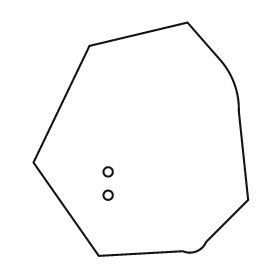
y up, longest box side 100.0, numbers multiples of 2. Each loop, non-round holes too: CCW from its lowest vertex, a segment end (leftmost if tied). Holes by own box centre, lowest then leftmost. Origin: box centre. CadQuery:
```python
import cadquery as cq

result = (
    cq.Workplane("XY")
    .moveTo(-18.0, -50.0)
    .lineTo(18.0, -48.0)
    .threePointArc((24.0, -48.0), (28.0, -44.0))
    .lineTo(46.0, -26.0)
    .lineTo(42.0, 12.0)
    .threePointArc((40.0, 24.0), (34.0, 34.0))
    .lineTo(20.0, 50.0)
    .lineTo(-22.0, 40.0)
    .lineTo(-46.0, -10.0)
    .close()
    .moveTo(-14.0, -24.0)
    .circle(2.0)
    .moveTo(-14.0, -14.0)
    .circle(2.0)
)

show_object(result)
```